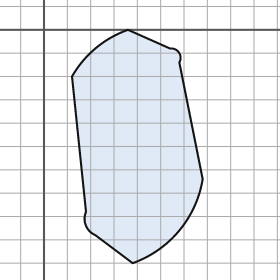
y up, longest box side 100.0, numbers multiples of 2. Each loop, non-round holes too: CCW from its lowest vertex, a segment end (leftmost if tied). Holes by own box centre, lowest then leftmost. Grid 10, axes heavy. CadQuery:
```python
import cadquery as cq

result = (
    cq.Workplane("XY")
    .moveTo(38.0, -100.0)
    .threePointArc((58.0, -86.0), (68.0, -64.0))
    .lineTo(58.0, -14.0)
    .threePointArc((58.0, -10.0), (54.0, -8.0))
    .lineTo(36.0, 0.0)
    .threePointArc((22.0, -8.0), (12.0, -20.0))
    .lineTo(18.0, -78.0)
    .threePointArc((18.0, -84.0), (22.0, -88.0))
    .close()
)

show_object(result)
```